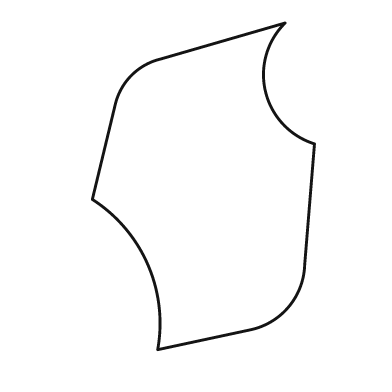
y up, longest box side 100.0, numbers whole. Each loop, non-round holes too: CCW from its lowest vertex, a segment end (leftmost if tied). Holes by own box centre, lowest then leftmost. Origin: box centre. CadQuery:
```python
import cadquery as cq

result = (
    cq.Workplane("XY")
    .moveTo(-14.0, -50.0)
    .lineTo(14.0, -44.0)
    .threePointArc((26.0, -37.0), (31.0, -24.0))
    .lineTo(34.0, 13.0)
    .threePointArc((19.0, 29.0), (25.0, 50.0))
    .lineTo(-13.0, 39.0)
    .threePointArc((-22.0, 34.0), (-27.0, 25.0))
    .lineTo(-34.0, -4.0)
    .threePointArc((-17.0, -24.0), (-14.0, -50.0))
    .close()
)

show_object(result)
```